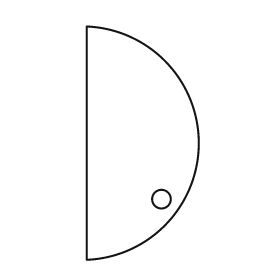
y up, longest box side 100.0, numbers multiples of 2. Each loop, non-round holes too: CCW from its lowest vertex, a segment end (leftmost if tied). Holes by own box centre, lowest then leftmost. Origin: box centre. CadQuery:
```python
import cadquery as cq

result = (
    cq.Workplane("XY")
    .moveTo(-24.0, -50.0)
    .threePointArc((24.0, 0.0), (-24.0, 50.0))
    .close()
    .moveTo(8.0, -24.0)
    .circle(4.0)
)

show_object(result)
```